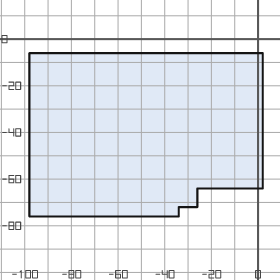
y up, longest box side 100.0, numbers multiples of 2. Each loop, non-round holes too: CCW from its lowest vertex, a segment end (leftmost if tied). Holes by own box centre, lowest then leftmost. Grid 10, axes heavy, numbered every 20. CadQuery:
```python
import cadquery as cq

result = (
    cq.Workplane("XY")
    .moveTo(-98.0, -76.0)
    .lineTo(-34.0, -76.0)
    .lineTo(-34.0, -72.0)
    .lineTo(-26.0, -72.0)
    .lineTo(-26.0, -64.0)
    .lineTo(2.0, -64.0)
    .lineTo(2.0, -6.0)
    .lineTo(-98.0, -6.0)
    .close()
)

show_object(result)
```